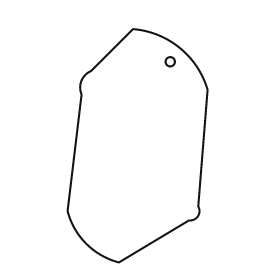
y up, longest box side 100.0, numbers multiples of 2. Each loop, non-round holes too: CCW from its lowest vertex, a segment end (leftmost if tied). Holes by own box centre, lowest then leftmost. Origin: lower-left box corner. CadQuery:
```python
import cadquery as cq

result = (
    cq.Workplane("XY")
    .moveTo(22.0, 0.0)
    .lineTo(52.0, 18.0)
    .threePointArc((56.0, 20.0), (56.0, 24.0))
    .lineTo(60.0, 74.0)
    .threePointArc((48.0, 92.0), (28.0, 100.0))
    .lineTo(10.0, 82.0)
    .threePointArc((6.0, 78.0), (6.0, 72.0))
    .lineTo(0.0, 22.0)
    .threePointArc((8.0, 8.0), (22.0, 0.0))
    .close()
    .moveTo(44.0, 86.0)
    .circle(2.0)
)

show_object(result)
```